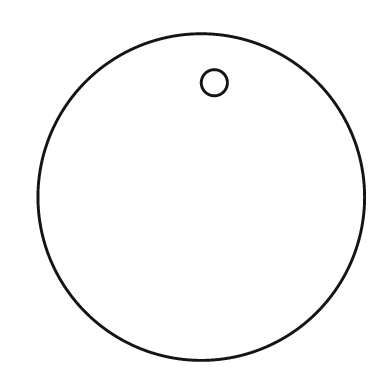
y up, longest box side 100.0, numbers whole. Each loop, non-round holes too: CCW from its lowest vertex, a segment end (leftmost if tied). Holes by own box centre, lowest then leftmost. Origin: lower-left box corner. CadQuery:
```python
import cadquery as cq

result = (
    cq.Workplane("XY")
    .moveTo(50.0, 50.0)
    .circle(50.0)
    .moveTo(54.0, 85.0)
    .circle(4.0)
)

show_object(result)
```